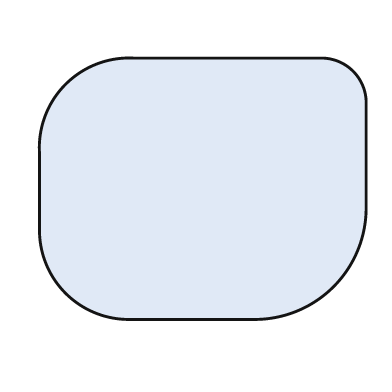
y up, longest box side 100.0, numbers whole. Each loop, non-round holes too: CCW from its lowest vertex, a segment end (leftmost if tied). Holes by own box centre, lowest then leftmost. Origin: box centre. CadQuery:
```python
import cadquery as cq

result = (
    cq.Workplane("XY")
    .moveTo(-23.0, -40.0)
    .lineTo(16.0, -40.0)
    .threePointArc((40.0, -30.0), (50.0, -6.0))
    .lineTo(50.0, 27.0)
    .threePointArc((46.0, 36.0), (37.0, 40.0))
    .lineTo(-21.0, 40.0)
    .threePointArc((-42.0, 32.0), (-50.0, 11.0))
    .lineTo(-50.0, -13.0)
    .threePointArc((-42.0, -32.0), (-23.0, -40.0))
    .close()
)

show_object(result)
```